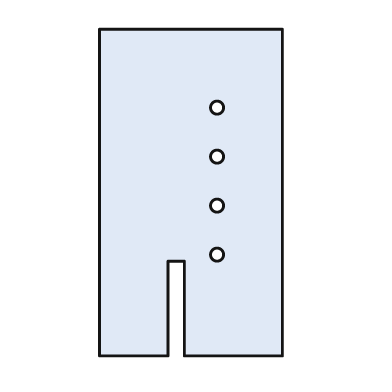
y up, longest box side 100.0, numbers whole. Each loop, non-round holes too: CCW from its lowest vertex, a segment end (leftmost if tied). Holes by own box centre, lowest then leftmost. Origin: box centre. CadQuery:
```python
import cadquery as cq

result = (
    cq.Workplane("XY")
    .moveTo(-28.0, -50.0)
    .lineTo(-7.0, -50.0)
    .lineTo(-7.0, -21.0)
    .lineTo(-2.0, -21.0)
    .lineTo(-2.0, -50.0)
    .lineTo(28.0, -50.0)
    .lineTo(28.0, 50.0)
    .lineTo(-28.0, 50.0)
    .close()
    .moveTo(8.0, -19.0)
    .circle(2.0)
    .moveTo(8.0, -4.0)
    .circle(2.0)
    .moveTo(8.0, 11.0)
    .circle(2.0)
    .moveTo(8.0, 26.0)
    .circle(2.0)
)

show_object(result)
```